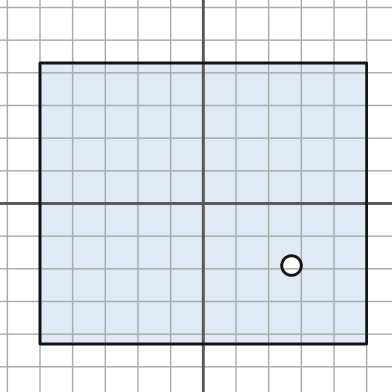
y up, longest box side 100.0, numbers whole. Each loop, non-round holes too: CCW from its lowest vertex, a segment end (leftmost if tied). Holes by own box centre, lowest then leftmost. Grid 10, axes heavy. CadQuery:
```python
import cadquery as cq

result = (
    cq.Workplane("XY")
    .moveTo(-50.0, -43.0)
    .lineTo(50.0, -43.0)
    .lineTo(50.0, 43.0)
    .lineTo(-50.0, 43.0)
    .close()
    .moveTo(27.0, -19.0)
    .circle(3.0)
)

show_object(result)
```